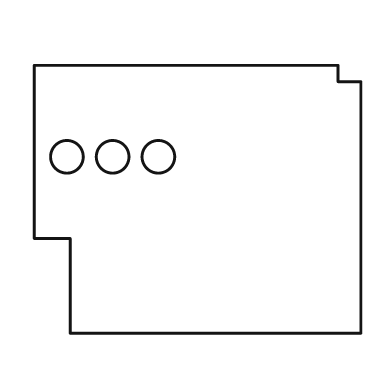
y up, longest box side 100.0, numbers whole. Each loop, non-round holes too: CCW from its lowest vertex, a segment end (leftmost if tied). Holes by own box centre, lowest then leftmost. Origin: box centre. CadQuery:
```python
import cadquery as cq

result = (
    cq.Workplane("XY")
    .moveTo(-39.0, -41.0)
    .lineTo(50.0, -41.0)
    .lineTo(50.0, 36.0)
    .lineTo(43.0, 36.0)
    .lineTo(43.0, 41.0)
    .lineTo(-50.0, 41.0)
    .lineTo(-50.0, -12.0)
    .lineTo(-39.0, -12.0)
    .close()
    .moveTo(-40.0, 13.0)
    .circle(5.0)
    .moveTo(-26.0, 13.0)
    .circle(5.0)
    .moveTo(-12.0, 13.0)
    .circle(5.0)
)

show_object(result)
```